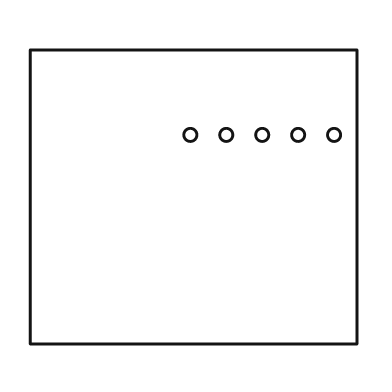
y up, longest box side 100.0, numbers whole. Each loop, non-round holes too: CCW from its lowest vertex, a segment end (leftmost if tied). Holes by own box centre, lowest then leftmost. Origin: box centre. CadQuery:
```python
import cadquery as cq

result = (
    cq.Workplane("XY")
    .moveTo(-50.0, -45.0)
    .lineTo(50.0, -45.0)
    .lineTo(50.0, 45.0)
    .lineTo(-50.0, 45.0)
    .close()
    .moveTo(-1.0, 19.0)
    .circle(2.0)
    .moveTo(10.0, 19.0)
    .circle(2.0)
    .moveTo(21.0, 19.0)
    .circle(2.0)
    .moveTo(32.0, 19.0)
    .circle(2.0)
    .moveTo(43.0, 19.0)
    .circle(2.0)
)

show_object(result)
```